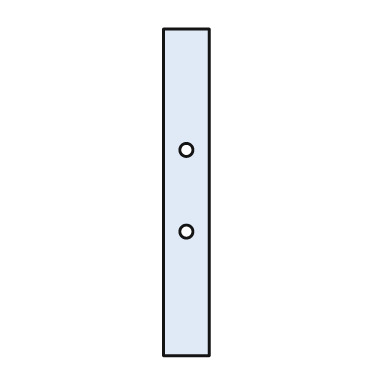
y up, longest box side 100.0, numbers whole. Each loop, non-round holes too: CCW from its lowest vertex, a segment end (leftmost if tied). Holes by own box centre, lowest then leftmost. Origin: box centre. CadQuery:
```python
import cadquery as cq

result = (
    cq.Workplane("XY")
    .moveTo(-7.0, -50.0)
    .lineTo(7.0, -50.0)
    .lineTo(7.0, 50.0)
    .lineTo(-7.0, 50.0)
    .close()
    .moveTo(0.0, -12.0)
    .circle(2.0)
    .moveTo(0.0, 13.0)
    .circle(2.0)
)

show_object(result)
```